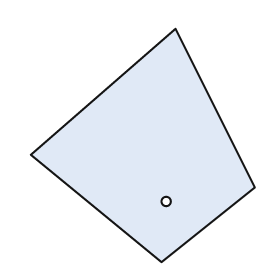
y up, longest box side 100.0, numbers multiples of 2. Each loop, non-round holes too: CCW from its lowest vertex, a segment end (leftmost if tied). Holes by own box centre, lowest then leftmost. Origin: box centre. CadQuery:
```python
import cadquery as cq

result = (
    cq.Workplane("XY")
    .moveTo(8.0, -50.0)
    .lineTo(48.0, -18.0)
    .lineTo(14.0, 50.0)
    .lineTo(-48.0, -4.0)
    .close()
    .moveTo(10.0, -24.0)
    .circle(2.0)
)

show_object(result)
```